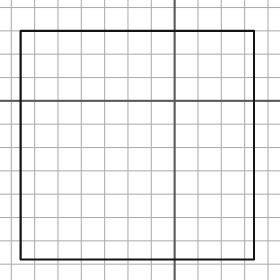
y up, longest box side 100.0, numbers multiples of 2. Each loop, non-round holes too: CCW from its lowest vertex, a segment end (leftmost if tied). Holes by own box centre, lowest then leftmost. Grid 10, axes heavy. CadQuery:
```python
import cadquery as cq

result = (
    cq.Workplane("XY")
    .moveTo(-66.0, -68.0)
    .lineTo(34.0, -68.0)
    .lineTo(34.0, 30.0)
    .lineTo(-66.0, 30.0)
    .close()
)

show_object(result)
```